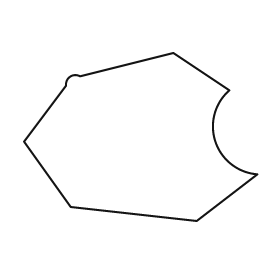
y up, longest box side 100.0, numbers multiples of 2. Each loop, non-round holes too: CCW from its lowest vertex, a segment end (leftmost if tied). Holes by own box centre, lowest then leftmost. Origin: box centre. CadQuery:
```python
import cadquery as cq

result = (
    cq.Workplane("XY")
    .moveTo(24.0, -36.0)
    .lineTo(50.0, -16.0)
    .threePointArc((32.0, -2.0), (38.0, 20.0))
    .lineTo(14.0, 36.0)
    .lineTo(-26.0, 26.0)
    .threePointArc((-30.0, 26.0), (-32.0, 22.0))
    .lineTo(-50.0, -2.0)
    .lineTo(-30.0, -30.0)
    .close()
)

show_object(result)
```